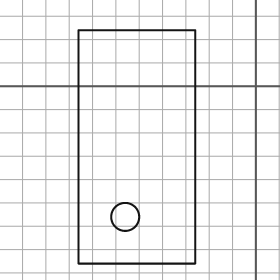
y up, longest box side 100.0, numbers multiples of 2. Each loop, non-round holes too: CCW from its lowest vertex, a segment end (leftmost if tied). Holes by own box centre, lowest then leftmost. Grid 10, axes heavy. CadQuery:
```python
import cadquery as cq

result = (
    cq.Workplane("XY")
    .moveTo(-76.0, -76.0)
    .lineTo(-26.0, -76.0)
    .lineTo(-26.0, 24.0)
    .lineTo(-76.0, 24.0)
    .close()
    .moveTo(-56.0, -56.0)
    .circle(6.0)
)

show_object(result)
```